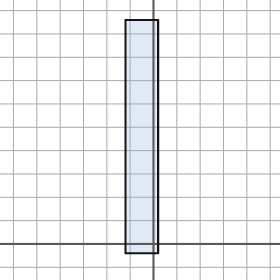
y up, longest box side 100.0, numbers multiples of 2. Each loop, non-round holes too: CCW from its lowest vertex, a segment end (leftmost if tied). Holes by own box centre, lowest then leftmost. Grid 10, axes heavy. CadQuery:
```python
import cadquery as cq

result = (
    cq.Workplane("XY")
    .moveTo(-12.0, -4.0)
    .lineTo(2.0, -4.0)
    .lineTo(2.0, 96.0)
    .lineTo(-12.0, 96.0)
    .close()
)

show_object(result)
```